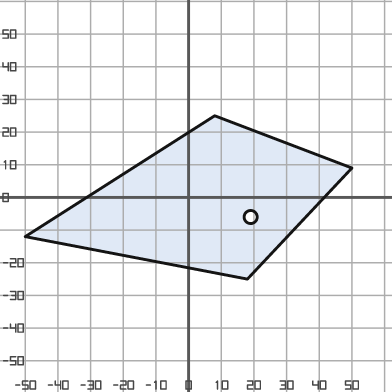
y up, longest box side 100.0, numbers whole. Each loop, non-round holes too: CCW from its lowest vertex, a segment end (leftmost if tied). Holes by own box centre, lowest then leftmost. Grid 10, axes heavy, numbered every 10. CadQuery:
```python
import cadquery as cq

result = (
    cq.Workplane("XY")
    .moveTo(18.0, -25.0)
    .lineTo(50.0, 9.0)
    .lineTo(8.0, 25.0)
    .lineTo(-50.0, -12.0)
    .close()
    .moveTo(19.0, -6.0)
    .circle(2.0)
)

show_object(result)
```